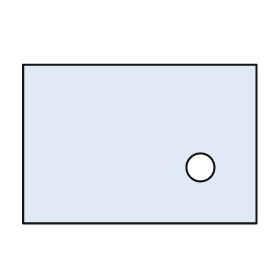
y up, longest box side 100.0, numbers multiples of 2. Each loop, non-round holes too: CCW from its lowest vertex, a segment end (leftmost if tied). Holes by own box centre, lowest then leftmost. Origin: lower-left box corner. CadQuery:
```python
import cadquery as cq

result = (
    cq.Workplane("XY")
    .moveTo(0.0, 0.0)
    .lineTo(100.0, 0.0)
    .lineTo(100.0, 68.0)
    .lineTo(0.0, 68.0)
    .close()
    .moveTo(76.0, 24.0)
    .circle(6.0)
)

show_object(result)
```